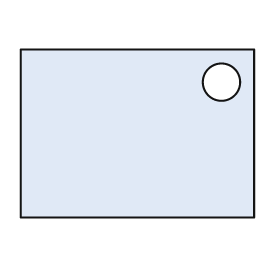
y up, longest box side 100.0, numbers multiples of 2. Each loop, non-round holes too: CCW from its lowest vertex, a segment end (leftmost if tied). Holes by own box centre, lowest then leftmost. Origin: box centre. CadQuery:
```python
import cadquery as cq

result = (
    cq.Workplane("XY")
    .moveTo(-50.0, -36.0)
    .lineTo(50.0, -36.0)
    .lineTo(50.0, 36.0)
    .lineTo(-50.0, 36.0)
    .close()
    .moveTo(36.0, 22.0)
    .circle(8.0)
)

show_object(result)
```